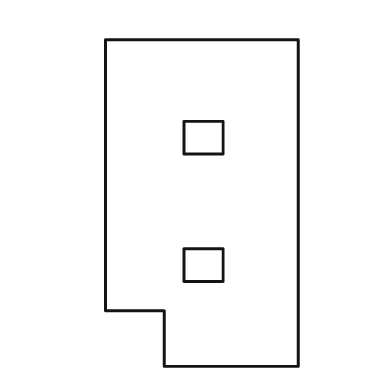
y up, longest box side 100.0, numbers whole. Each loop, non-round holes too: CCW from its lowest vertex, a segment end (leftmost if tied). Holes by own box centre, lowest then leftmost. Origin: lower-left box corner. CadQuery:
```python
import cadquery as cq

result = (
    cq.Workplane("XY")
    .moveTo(18.0, 0.0)
    .lineTo(59.0, 0.0)
    .lineTo(59.0, 100.0)
    .lineTo(0.0, 100.0)
    .lineTo(0.0, 17.0)
    .lineTo(18.0, 17.0)
    .close()
    .moveTo(24.0, 26.0)
    .lineTo(36.0, 26.0)
    .lineTo(36.0, 36.0)
    .lineTo(24.0, 36.0)
    .close()
    .moveTo(24.0, 65.0)
    .lineTo(36.0, 65.0)
    .lineTo(36.0, 75.0)
    .lineTo(24.0, 75.0)
    .close()
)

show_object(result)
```